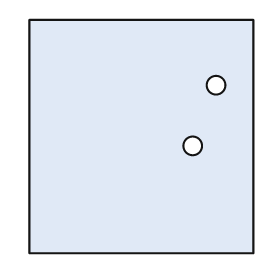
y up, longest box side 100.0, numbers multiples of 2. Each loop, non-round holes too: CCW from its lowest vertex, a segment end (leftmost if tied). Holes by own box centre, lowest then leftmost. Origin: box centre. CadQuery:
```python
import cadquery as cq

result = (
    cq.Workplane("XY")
    .moveTo(-48.0, -50.0)
    .lineTo(48.0, -50.0)
    .lineTo(48.0, 50.0)
    .lineTo(-48.0, 50.0)
    .close()
    .moveTo(22.0, -4.0)
    .circle(4.0)
    .moveTo(32.0, 22.0)
    .circle(4.0)
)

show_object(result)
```